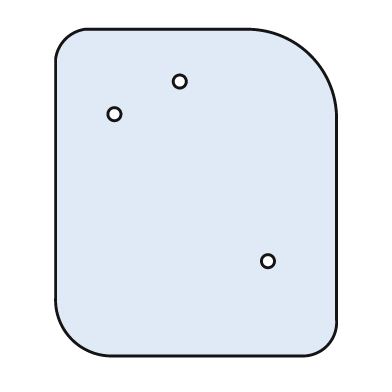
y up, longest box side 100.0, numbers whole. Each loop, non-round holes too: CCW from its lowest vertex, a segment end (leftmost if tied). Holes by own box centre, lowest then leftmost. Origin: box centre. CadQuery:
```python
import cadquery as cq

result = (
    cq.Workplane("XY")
    .moveTo(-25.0, -50.0)
    .lineTo(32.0, -50.0)
    .threePointArc((40.0, -47.0), (43.0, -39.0))
    .lineTo(43.0, 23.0)
    .threePointArc((35.0, 42.0), (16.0, 50.0))
    .lineTo(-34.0, 50.0)
    .threePointArc((-40.0, 47.0), (-43.0, 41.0))
    .lineTo(-43.0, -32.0)
    .threePointArc((-38.0, -45.0), (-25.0, -50.0))
    .close()
    .moveTo(22.0, -21.0)
    .circle(2.0)
    .moveTo(-25.0, 24.0)
    .circle(2.0)
    .moveTo(-5.0, 34.0)
    .circle(2.0)
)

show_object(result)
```